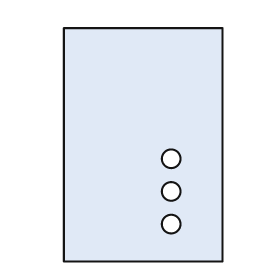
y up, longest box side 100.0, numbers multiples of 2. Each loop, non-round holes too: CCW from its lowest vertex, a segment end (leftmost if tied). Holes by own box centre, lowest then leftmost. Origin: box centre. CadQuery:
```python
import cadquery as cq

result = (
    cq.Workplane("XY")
    .moveTo(-34.0, -50.0)
    .lineTo(34.0, -50.0)
    .lineTo(34.0, 50.0)
    .lineTo(-34.0, 50.0)
    .close()
    .moveTo(12.0, -34.0)
    .circle(4.0)
    .moveTo(12.0, -20.0)
    .circle(4.0)
    .moveTo(12.0, -6.0)
    .circle(4.0)
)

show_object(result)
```